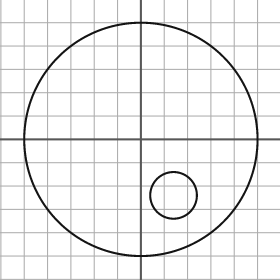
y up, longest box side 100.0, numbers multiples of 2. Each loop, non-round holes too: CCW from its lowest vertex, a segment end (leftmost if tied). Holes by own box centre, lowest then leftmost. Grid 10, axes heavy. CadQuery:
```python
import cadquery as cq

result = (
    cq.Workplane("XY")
    .moveTo(0.0, 0.0)
    .circle(50.0)
    .moveTo(14.0, -24.0)
    .circle(10.0)
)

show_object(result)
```